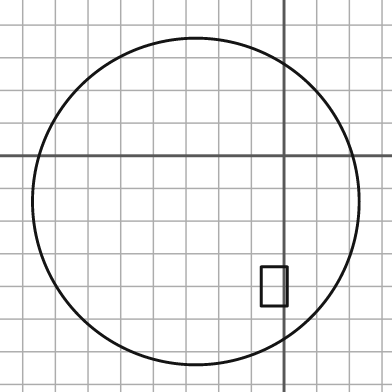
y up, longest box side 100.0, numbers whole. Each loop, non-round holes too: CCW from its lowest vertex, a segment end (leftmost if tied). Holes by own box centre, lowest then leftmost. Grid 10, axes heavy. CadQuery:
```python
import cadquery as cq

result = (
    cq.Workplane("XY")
    .moveTo(-27.0, -14.0)
    .circle(50.0)
    .moveTo(-7.0, -46.0)
    .lineTo(1.0, -46.0)
    .lineTo(1.0, -34.0)
    .lineTo(-7.0, -34.0)
    .close()
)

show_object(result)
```